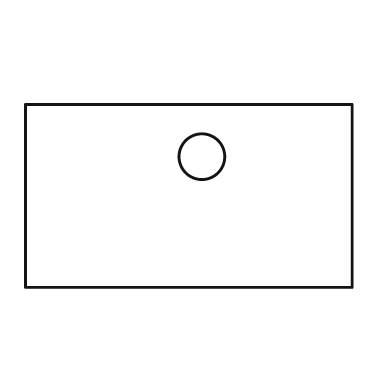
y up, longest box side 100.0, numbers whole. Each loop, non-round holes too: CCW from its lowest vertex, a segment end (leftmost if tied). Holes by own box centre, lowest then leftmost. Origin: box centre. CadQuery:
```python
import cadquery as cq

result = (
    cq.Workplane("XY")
    .moveTo(-50.0, -28.0)
    .lineTo(50.0, -28.0)
    .lineTo(50.0, 28.0)
    .lineTo(-50.0, 28.0)
    .close()
    .moveTo(4.0, 12.0)
    .circle(7.0)
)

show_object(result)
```